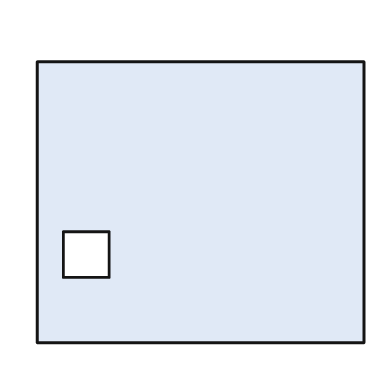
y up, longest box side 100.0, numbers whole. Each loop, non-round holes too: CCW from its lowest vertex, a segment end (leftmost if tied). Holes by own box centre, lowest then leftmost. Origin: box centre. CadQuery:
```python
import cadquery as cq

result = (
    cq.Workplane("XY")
    .moveTo(-50.0, -43.0)
    .lineTo(50.0, -43.0)
    .lineTo(50.0, 43.0)
    .lineTo(-50.0, 43.0)
    .close()
    .moveTo(-42.0, -23.0)
    .lineTo(-28.0, -23.0)
    .lineTo(-28.0, -9.0)
    .lineTo(-42.0, -9.0)
    .close()
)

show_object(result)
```